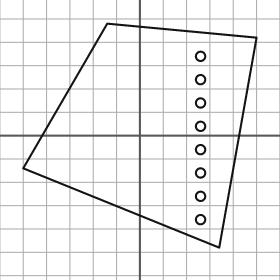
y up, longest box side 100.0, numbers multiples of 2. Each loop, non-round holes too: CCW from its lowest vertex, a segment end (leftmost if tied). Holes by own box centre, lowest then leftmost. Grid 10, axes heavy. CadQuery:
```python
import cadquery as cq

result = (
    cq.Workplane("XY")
    .moveTo(34.0, -48.0)
    .lineTo(50.0, 42.0)
    .lineTo(-14.0, 48.0)
    .lineTo(-50.0, -14.0)
    .close()
    .moveTo(26.0, -36.0)
    .circle(2.0)
    .moveTo(26.0, -26.0)
    .circle(2.0)
    .moveTo(26.0, -16.0)
    .circle(2.0)
    .moveTo(26.0, -6.0)
    .circle(2.0)
    .moveTo(26.0, 4.0)
    .circle(2.0)
    .moveTo(26.0, 14.0)
    .circle(2.0)
    .moveTo(26.0, 24.0)
    .circle(2.0)
    .moveTo(26.0, 34.0)
    .circle(2.0)
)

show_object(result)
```